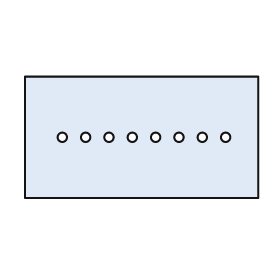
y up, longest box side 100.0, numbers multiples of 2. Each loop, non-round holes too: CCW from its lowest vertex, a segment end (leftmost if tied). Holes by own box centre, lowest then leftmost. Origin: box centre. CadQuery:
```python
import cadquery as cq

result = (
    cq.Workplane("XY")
    .moveTo(-50.0, -26.0)
    .lineTo(50.0, -26.0)
    .lineTo(50.0, 26.0)
    .lineTo(-50.0, 26.0)
    .close()
    .moveTo(-34.0, 0.0)
    .circle(2.0)
    .moveTo(-24.0, 0.0)
    .circle(2.0)
    .moveTo(-14.0, 0.0)
    .circle(2.0)
    .moveTo(-4.0, 0.0)
    .circle(2.0)
    .moveTo(6.0, 0.0)
    .circle(2.0)
    .moveTo(16.0, 0.0)
    .circle(2.0)
    .moveTo(26.0, 0.0)
    .circle(2.0)
    .moveTo(36.0, 0.0)
    .circle(2.0)
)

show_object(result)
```